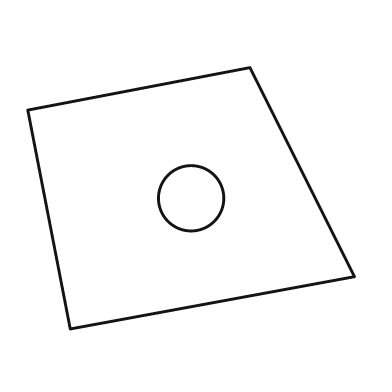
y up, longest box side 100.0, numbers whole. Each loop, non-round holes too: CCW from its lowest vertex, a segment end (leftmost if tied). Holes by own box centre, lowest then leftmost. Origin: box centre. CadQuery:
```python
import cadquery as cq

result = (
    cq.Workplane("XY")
    .moveTo(-37.0, -40.0)
    .lineTo(50.0, -24.0)
    .lineTo(18.0, 40.0)
    .lineTo(-50.0, 27.0)
    .close()
    .moveTo(0.0, 0.0)
    .circle(10.0)
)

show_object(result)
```